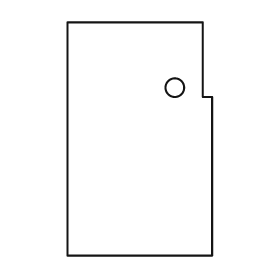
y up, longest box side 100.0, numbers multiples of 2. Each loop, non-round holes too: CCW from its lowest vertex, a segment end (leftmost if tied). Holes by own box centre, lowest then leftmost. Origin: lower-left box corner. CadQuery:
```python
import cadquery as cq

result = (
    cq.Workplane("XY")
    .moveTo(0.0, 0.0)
    .lineTo(62.0, 0.0)
    .lineTo(62.0, 68.0)
    .lineTo(58.0, 68.0)
    .lineTo(58.0, 100.0)
    .lineTo(0.0, 100.0)
    .close()
    .moveTo(46.0, 72.0)
    .circle(4.0)
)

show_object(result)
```